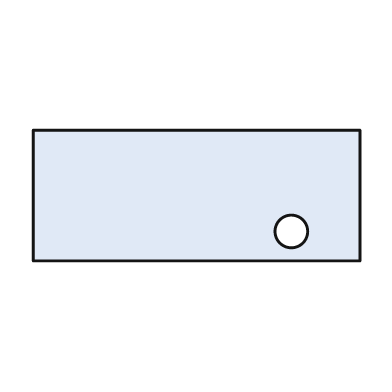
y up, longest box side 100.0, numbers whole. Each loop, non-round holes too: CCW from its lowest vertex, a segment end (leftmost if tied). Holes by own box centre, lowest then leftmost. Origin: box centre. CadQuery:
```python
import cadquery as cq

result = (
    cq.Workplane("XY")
    .moveTo(-50.0, -20.0)
    .lineTo(50.0, -20.0)
    .lineTo(50.0, 20.0)
    .lineTo(-50.0, 20.0)
    .close()
    .moveTo(29.0, -11.0)
    .circle(5.0)
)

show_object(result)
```